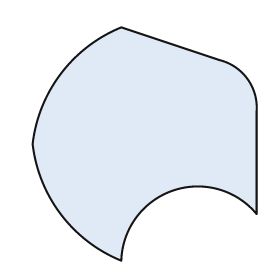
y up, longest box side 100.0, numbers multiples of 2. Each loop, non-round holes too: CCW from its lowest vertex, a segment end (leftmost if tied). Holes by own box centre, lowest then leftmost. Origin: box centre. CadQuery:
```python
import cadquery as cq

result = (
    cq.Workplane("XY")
    .moveTo(-10.0, -50.0)
    .threePointArc((12.0, -20.0), (48.0, -30.0))
    .lineTo(48.0, 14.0)
    .threePointArc((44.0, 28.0), (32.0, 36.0))
    .lineTo(-10.0, 50.0)
    .threePointArc((-36.0, 30.0), (-48.0, 0.0))
    .threePointArc((-36.0, -30.0), (-10.0, -50.0))
    .close()
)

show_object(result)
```